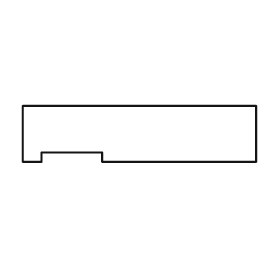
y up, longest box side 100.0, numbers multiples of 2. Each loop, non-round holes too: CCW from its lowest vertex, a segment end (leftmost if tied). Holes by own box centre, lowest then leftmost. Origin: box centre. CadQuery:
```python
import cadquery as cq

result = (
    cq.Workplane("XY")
    .moveTo(-50.0, -12.0)
    .lineTo(-42.0, -12.0)
    .lineTo(-42.0, -8.0)
    .lineTo(-16.0, -8.0)
    .lineTo(-16.0, -12.0)
    .lineTo(50.0, -12.0)
    .lineTo(50.0, 12.0)
    .lineTo(-50.0, 12.0)
    .close()
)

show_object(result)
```